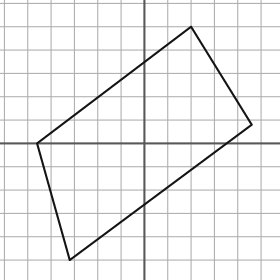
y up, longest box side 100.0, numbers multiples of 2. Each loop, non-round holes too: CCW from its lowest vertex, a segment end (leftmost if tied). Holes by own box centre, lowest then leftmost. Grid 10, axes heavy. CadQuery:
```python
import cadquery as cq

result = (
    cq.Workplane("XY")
    .moveTo(-32.0, -50.0)
    .lineTo(46.0, 8.0)
    .lineTo(20.0, 50.0)
    .lineTo(-46.0, 0.0)
    .close()
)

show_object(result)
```